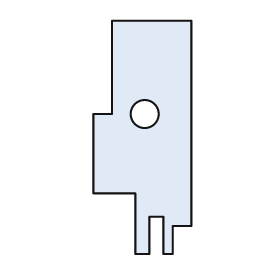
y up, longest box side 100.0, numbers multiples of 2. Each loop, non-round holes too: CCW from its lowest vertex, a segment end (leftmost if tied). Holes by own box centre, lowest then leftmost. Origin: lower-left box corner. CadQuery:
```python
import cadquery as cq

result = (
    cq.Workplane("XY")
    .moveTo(18.0, 0.0)
    .lineTo(24.0, 0.0)
    .lineTo(24.0, 16.0)
    .lineTo(30.0, 16.0)
    .lineTo(30.0, 0.0)
    .lineTo(34.0, 0.0)
    .lineTo(34.0, 12.0)
    .lineTo(42.0, 12.0)
    .lineTo(42.0, 100.0)
    .lineTo(8.0, 100.0)
    .lineTo(8.0, 60.0)
    .lineTo(0.0, 60.0)
    .lineTo(0.0, 26.0)
    .lineTo(18.0, 26.0)
    .close()
    .moveTo(22.0, 60.0)
    .circle(6.0)
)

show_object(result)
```